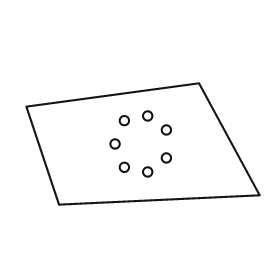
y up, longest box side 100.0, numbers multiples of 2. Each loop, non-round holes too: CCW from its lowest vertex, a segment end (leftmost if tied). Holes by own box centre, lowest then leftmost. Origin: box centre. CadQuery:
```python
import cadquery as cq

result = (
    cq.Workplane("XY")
    .moveTo(-36.0, -26.0)
    .lineTo(50.0, -22.0)
    .lineTo(24.0, 26.0)
    .lineTo(-50.0, 16.0)
    .close()
    .moveTo(2.0, -12.0)
    .circle(2.0)
    .moveTo(-8.0, -10.0)
    .circle(2.0)
    .moveTo(10.0, -6.0)
    .circle(2.0)
    .moveTo(-12.0, 0.0)
    .circle(2.0)
    .moveTo(10.0, 6.0)
    .circle(2.0)
    .moveTo(-8.0, 10.0)
    .circle(2.0)
    .moveTo(2.0, 12.0)
    .circle(2.0)
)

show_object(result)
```